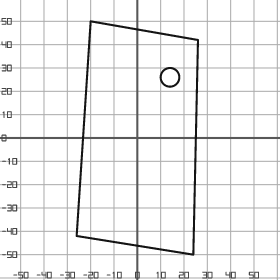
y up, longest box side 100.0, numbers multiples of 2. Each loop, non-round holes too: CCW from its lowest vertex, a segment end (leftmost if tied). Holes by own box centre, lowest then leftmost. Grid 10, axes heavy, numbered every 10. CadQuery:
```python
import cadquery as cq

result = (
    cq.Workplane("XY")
    .moveTo(24.0, -50.0)
    .lineTo(26.0, 42.0)
    .lineTo(-20.0, 50.0)
    .lineTo(-26.0, -42.0)
    .close()
    .moveTo(14.0, 26.0)
    .circle(4.0)
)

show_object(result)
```